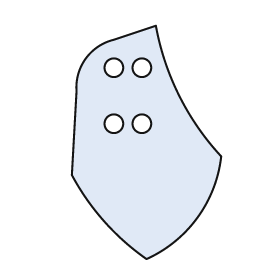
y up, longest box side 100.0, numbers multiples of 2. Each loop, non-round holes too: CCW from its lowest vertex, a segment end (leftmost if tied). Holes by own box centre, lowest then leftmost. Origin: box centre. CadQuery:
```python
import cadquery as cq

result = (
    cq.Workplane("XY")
    .moveTo(0.0, -50.0)
    .threePointArc((22.0, -32.0), (32.0, -6.0))
    .threePointArc((14.0, 20.0), (4.0, 50.0))
    .lineTo(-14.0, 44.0)
    .threePointArc((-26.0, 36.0), (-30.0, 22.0))
    .lineTo(-32.0, -14.0)
    .threePointArc((-18.0, -34.0), (0.0, -50.0))
    .close()
    .moveTo(-14.0, 8.0)
    .circle(4.0)
    .moveTo(-2.0, 8.0)
    .circle(4.0)
    .moveTo(-14.0, 32.0)
    .circle(4.0)
    .moveTo(-2.0, 32.0)
    .circle(4.0)
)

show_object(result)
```